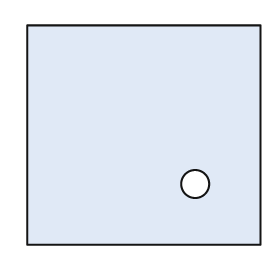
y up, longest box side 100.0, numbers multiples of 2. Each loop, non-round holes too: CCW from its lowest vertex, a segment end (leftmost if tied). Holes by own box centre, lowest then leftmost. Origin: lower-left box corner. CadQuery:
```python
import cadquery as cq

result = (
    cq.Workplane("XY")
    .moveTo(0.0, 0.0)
    .lineTo(100.0, 0.0)
    .lineTo(100.0, 94.0)
    .lineTo(0.0, 94.0)
    .close()
    .moveTo(72.0, 26.0)
    .circle(6.0)
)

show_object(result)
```